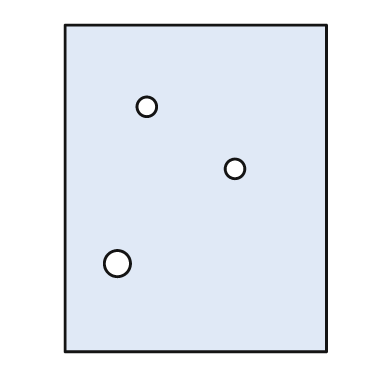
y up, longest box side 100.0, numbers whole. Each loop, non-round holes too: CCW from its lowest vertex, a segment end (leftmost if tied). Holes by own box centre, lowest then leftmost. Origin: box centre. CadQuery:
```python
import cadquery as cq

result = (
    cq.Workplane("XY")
    .moveTo(-40.0, -50.0)
    .lineTo(40.0, -50.0)
    .lineTo(40.0, 50.0)
    .lineTo(-40.0, 50.0)
    .close()
    .moveTo(-24.0, -23.0)
    .circle(4.0)
    .moveTo(12.0, 6.0)
    .circle(3.0)
    .moveTo(-15.0, 25.0)
    .circle(3.0)
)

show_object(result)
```